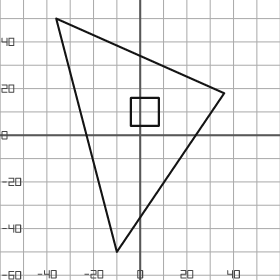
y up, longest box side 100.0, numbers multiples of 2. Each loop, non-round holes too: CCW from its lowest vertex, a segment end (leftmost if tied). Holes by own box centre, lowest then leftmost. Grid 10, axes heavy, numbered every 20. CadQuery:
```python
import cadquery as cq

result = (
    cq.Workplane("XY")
    .moveTo(-10.0, -50.0)
    .lineTo(36.0, 18.0)
    .lineTo(-36.0, 50.0)
    .close()
    .moveTo(-4.0, 4.0)
    .lineTo(8.0, 4.0)
    .lineTo(8.0, 16.0)
    .lineTo(-4.0, 16.0)
    .close()
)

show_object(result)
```